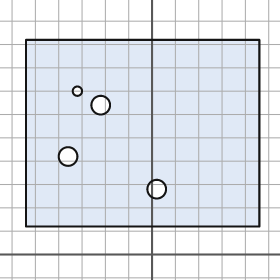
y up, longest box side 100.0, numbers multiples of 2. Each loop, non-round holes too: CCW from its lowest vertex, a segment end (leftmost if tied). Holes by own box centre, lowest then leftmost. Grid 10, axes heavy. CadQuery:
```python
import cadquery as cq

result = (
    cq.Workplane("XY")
    .moveTo(-54.0, 12.0)
    .lineTo(46.0, 12.0)
    .lineTo(46.0, 92.0)
    .lineTo(-54.0, 92.0)
    .close()
    .moveTo(2.0, 28.0)
    .circle(4.0)
    .moveTo(-36.0, 42.0)
    .circle(4.0)
    .moveTo(-22.0, 64.0)
    .circle(4.0)
    .moveTo(-32.0, 70.0)
    .circle(2.0)
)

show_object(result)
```